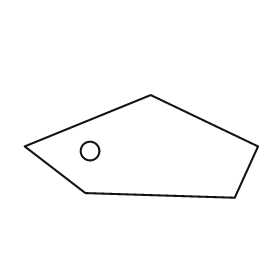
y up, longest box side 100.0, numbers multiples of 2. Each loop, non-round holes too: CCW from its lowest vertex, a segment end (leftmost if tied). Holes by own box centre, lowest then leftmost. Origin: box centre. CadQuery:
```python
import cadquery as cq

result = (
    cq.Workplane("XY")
    .moveTo(40.0, -22.0)
    .lineTo(50.0, 0.0)
    .lineTo(4.0, 22.0)
    .lineTo(-50.0, 0.0)
    .lineTo(-24.0, -20.0)
    .close()
    .moveTo(-22.0, -2.0)
    .circle(4.0)
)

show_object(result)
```